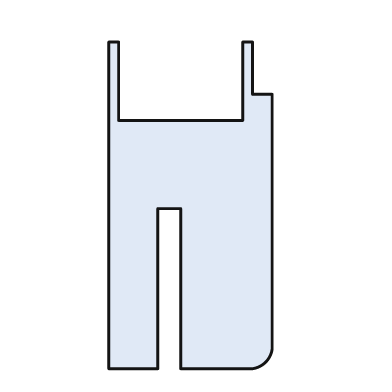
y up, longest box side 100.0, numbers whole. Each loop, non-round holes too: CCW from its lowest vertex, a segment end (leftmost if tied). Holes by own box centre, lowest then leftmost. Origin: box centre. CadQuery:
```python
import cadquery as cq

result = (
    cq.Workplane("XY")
    .moveTo(-25.0, -50.0)
    .lineTo(-10.0, -50.0)
    .lineTo(-10.0, -1.0)
    .lineTo(-3.0, -1.0)
    .lineTo(-3.0, -50.0)
    .lineTo(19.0, -50.0)
    .threePointArc((23.0, -48.0), (25.0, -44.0))
    .lineTo(25.0, 34.0)
    .lineTo(19.0, 34.0)
    .lineTo(19.0, 50.0)
    .lineTo(16.0, 50.0)
    .lineTo(16.0, 26.0)
    .lineTo(-22.0, 26.0)
    .lineTo(-22.0, 50.0)
    .lineTo(-25.0, 50.0)
    .close()
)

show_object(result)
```